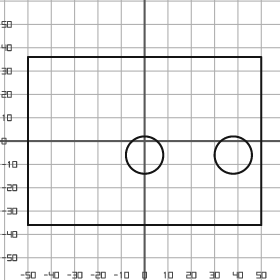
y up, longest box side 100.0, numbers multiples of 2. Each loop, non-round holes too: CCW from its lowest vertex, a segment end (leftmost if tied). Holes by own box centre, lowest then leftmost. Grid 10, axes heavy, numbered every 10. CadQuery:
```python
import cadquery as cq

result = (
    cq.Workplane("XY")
    .moveTo(-50.0, -36.0)
    .lineTo(50.0, -36.0)
    .lineTo(50.0, 36.0)
    .lineTo(-50.0, 36.0)
    .close()
    .moveTo(0.0, -6.0)
    .circle(8.0)
    .moveTo(38.0, -6.0)
    .circle(8.0)
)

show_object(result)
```